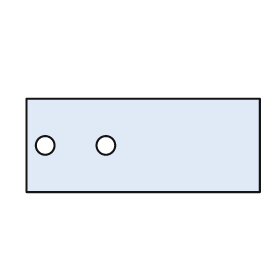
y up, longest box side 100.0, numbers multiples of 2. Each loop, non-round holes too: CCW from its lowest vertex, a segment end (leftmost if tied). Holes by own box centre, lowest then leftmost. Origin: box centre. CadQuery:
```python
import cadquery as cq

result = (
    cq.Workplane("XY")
    .moveTo(-50.0, -20.0)
    .lineTo(50.0, -20.0)
    .lineTo(50.0, 20.0)
    .lineTo(-50.0, 20.0)
    .close()
    .moveTo(-42.0, 0.0)
    .circle(4.0)
    .moveTo(-16.0, 0.0)
    .circle(4.0)
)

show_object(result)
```